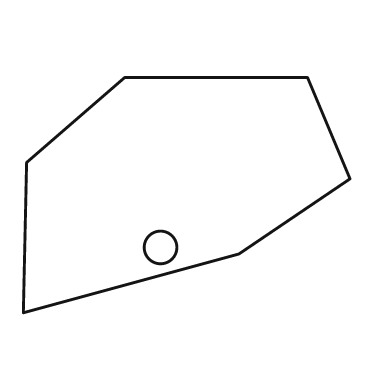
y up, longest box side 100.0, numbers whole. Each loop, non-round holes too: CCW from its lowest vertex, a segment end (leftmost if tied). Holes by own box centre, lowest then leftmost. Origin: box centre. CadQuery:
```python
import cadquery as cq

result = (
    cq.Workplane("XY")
    .moveTo(-50.0, -36.0)
    .lineTo(16.0, -18.0)
    .lineTo(50.0, 5.0)
    .lineTo(37.0, 36.0)
    .lineTo(-19.0, 36.0)
    .lineTo(-49.0, 10.0)
    .close()
    .moveTo(-8.0, -16.0)
    .circle(5.0)
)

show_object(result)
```